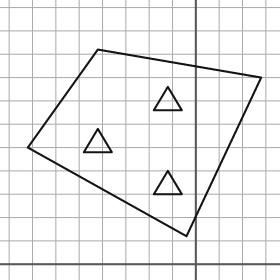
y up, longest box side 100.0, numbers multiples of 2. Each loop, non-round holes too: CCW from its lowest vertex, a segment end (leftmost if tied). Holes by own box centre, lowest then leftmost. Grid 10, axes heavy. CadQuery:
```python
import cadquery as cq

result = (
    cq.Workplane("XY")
    .moveTo(-4.0, 12.0)
    .lineTo(28.0, 80.0)
    .lineTo(-42.0, 92.0)
    .lineTo(-72.0, 50.0)
    .close()
    .moveTo(-18.0, 30.0)
    .lineTo(-6.0, 30.0)
    .lineTo(-12.0, 40.0)
    .close()
    .moveTo(-48.0, 48.0)
    .lineTo(-36.0, 48.0)
    .lineTo(-42.0, 58.0)
    .close()
    .moveTo(-18.0, 66.0)
    .lineTo(-6.0, 66.0)
    .lineTo(-12.0, 76.0)
    .close()
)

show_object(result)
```